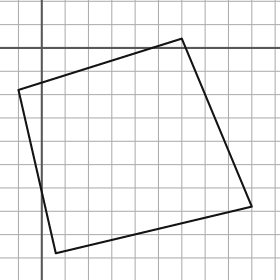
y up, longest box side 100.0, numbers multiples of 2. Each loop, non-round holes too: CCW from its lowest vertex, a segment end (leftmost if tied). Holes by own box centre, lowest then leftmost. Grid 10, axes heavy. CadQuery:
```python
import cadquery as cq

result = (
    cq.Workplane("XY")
    .moveTo(6.0, -88.0)
    .lineTo(90.0, -68.0)
    .lineTo(60.0, 4.0)
    .lineTo(-10.0, -18.0)
    .close()
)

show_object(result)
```